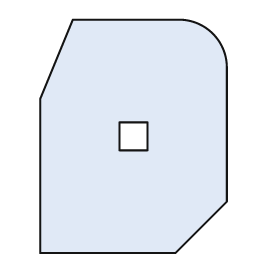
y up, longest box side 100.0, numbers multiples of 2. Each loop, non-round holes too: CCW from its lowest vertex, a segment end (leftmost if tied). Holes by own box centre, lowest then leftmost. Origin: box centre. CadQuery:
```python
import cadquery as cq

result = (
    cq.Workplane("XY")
    .moveTo(-40.0, -50.0)
    .lineTo(18.0, -50.0)
    .lineTo(40.0, -28.0)
    .lineTo(40.0, 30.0)
    .threePointArc((34.0, 44.0), (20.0, 50.0))
    .lineTo(-26.0, 50.0)
    .lineTo(-40.0, 16.0)
    .close()
    .moveTo(-6.0, -6.0)
    .lineTo(6.0, -6.0)
    .lineTo(6.0, 6.0)
    .lineTo(-6.0, 6.0)
    .close()
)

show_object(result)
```